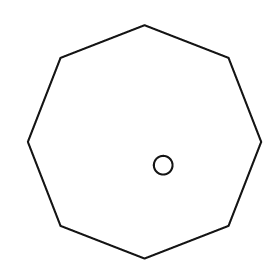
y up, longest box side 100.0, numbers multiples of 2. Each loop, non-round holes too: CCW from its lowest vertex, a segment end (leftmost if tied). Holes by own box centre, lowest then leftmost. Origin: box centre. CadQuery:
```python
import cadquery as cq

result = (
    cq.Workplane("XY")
    .moveTo(0.0, -50.0)
    .lineTo(36.0, -36.0)
    .lineTo(50.0, 0.0)
    .lineTo(36.0, 36.0)
    .lineTo(0.0, 50.0)
    .lineTo(-36.0, 36.0)
    .lineTo(-50.0, 0.0)
    .lineTo(-36.0, -36.0)
    .close()
    .moveTo(8.0, -10.0)
    .circle(4.0)
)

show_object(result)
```